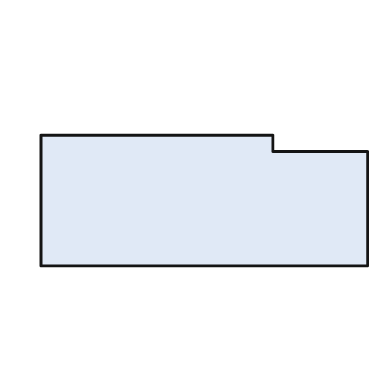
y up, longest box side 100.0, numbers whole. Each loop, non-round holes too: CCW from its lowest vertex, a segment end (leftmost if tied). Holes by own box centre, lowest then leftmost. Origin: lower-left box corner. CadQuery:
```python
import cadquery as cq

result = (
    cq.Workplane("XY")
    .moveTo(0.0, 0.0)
    .lineTo(100.0, 0.0)
    .lineTo(100.0, 35.0)
    .lineTo(71.0, 35.0)
    .lineTo(71.0, 40.0)
    .lineTo(0.0, 40.0)
    .close()
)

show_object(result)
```